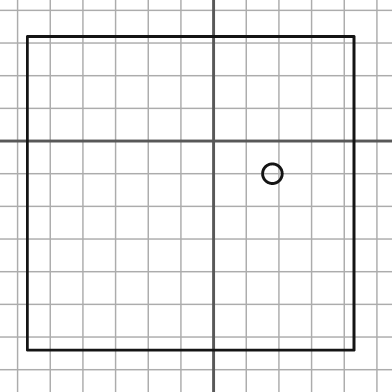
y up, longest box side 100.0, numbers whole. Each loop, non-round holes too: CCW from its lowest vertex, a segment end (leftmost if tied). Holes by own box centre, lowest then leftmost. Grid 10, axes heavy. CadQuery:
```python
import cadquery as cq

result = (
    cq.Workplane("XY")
    .moveTo(-57.0, -64.0)
    .lineTo(43.0, -64.0)
    .lineTo(43.0, 32.0)
    .lineTo(-57.0, 32.0)
    .close()
    .moveTo(18.0, -10.0)
    .circle(3.0)
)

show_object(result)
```